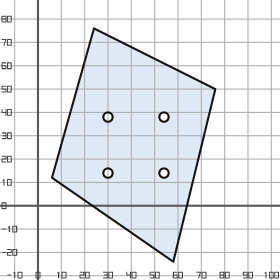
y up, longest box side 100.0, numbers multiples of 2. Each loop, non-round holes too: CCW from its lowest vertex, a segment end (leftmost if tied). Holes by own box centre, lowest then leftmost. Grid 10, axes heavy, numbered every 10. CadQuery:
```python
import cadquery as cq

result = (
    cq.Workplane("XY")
    .moveTo(58.0, -24.0)
    .lineTo(76.0, 50.0)
    .lineTo(24.0, 76.0)
    .lineTo(6.0, 12.0)
    .close()
    .moveTo(30.0, 14.0)
    .circle(2.0)
    .moveTo(54.0, 14.0)
    .circle(2.0)
    .moveTo(30.0, 38.0)
    .circle(2.0)
    .moveTo(54.0, 38.0)
    .circle(2.0)
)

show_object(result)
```